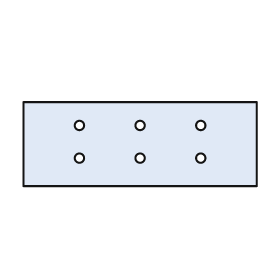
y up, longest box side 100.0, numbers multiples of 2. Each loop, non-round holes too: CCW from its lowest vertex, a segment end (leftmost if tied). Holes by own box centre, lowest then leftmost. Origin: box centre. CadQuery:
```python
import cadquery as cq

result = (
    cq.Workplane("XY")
    .moveTo(-50.0, -18.0)
    .lineTo(50.0, -18.0)
    .lineTo(50.0, 18.0)
    .lineTo(-50.0, 18.0)
    .close()
    .moveTo(-26.0, -6.0)
    .circle(2.0)
    .moveTo(0.0, -6.0)
    .circle(2.0)
    .moveTo(26.0, -6.0)
    .circle(2.0)
    .moveTo(-26.0, 8.0)
    .circle(2.0)
    .moveTo(0.0, 8.0)
    .circle(2.0)
    .moveTo(26.0, 8.0)
    .circle(2.0)
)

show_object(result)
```